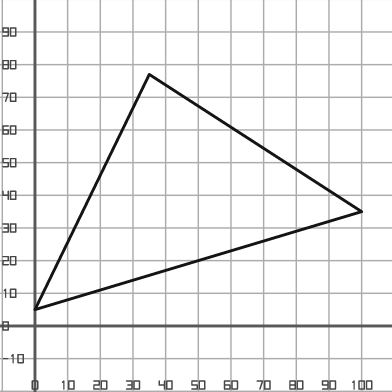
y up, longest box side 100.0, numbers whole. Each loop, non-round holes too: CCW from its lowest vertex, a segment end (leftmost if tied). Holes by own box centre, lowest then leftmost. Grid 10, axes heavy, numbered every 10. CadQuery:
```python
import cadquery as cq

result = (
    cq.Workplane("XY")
    .moveTo(0.0, 5.0)
    .lineTo(100.0, 35.0)
    .lineTo(35.0, 77.0)
    .close()
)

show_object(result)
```